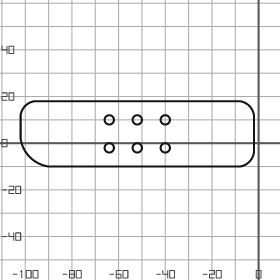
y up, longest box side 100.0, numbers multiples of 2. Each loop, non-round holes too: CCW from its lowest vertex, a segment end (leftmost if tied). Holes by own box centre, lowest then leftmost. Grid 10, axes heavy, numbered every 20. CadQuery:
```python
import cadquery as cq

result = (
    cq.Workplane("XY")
    .moveTo(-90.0, -10.0)
    .lineTo(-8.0, -10.0)
    .threePointArc((-4.0, -8.0), (-2.0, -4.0))
    .lineTo(-2.0, 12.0)
    .threePointArc((-4.0, 16.0), (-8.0, 18.0))
    .lineTo(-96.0, 18.0)
    .threePointArc((-100.0, 16.0), (-102.0, 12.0))
    .lineTo(-102.0, 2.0)
    .threePointArc((-98.0, -6.0), (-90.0, -10.0))
    .close()
    .moveTo(-64.0, -2.0)
    .circle(2.0)
    .moveTo(-52.0, -2.0)
    .circle(2.0)
    .moveTo(-40.0, -2.0)
    .circle(2.0)
    .moveTo(-64.0, 10.0)
    .circle(2.0)
    .moveTo(-52.0, 10.0)
    .circle(2.0)
    .moveTo(-40.0, 10.0)
    .circle(2.0)
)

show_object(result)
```